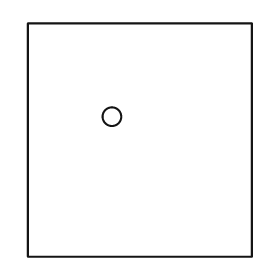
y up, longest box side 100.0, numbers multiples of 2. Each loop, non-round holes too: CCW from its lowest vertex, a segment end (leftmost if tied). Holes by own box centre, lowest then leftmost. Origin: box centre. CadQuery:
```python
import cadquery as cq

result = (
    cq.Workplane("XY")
    .moveTo(-48.0, -50.0)
    .lineTo(48.0, -50.0)
    .lineTo(48.0, 50.0)
    .lineTo(-48.0, 50.0)
    .close()
    .moveTo(-12.0, 10.0)
    .circle(4.0)
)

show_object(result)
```